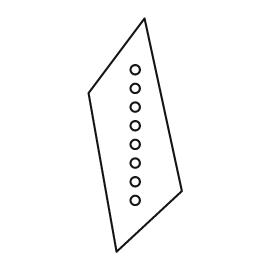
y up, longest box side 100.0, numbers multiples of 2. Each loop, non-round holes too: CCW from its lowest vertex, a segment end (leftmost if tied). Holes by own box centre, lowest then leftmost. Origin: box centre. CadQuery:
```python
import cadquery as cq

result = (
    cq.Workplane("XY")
    .moveTo(-8.0, -50.0)
    .lineTo(20.0, -24.0)
    .lineTo(4.0, 50.0)
    .lineTo(-20.0, 18.0)
    .close()
    .moveTo(0.0, -28.0)
    .circle(2.0)
    .moveTo(0.0, -20.0)
    .circle(2.0)
    .moveTo(0.0, -12.0)
    .circle(2.0)
    .moveTo(0.0, -4.0)
    .circle(2.0)
    .moveTo(0.0, 4.0)
    .circle(2.0)
    .moveTo(0.0, 12.0)
    .circle(2.0)
    .moveTo(0.0, 20.0)
    .circle(2.0)
    .moveTo(0.0, 28.0)
    .circle(2.0)
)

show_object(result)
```